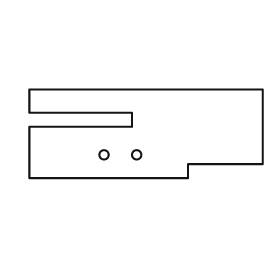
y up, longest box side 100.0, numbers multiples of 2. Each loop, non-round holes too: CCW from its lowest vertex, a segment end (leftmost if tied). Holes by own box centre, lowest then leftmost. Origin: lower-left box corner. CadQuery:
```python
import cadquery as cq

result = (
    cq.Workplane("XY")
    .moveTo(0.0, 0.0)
    .lineTo(68.0, 0.0)
    .lineTo(68.0, 6.0)
    .lineTo(100.0, 6.0)
    .lineTo(100.0, 38.0)
    .lineTo(0.0, 38.0)
    .lineTo(0.0, 28.0)
    .lineTo(44.0, 28.0)
    .lineTo(44.0, 22.0)
    .lineTo(0.0, 22.0)
    .close()
    .moveTo(32.0, 10.0)
    .circle(2.0)
    .moveTo(46.0, 10.0)
    .circle(2.0)
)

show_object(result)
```